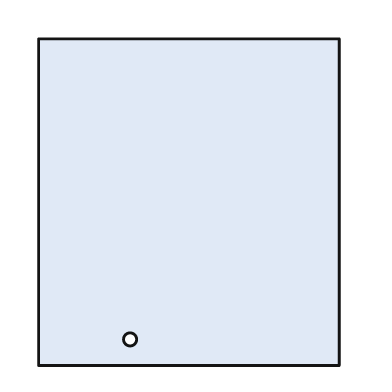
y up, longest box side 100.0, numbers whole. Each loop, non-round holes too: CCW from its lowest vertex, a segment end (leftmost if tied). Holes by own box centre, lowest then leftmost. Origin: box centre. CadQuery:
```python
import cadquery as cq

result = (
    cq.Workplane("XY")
    .moveTo(-46.0, -50.0)
    .lineTo(46.0, -50.0)
    .lineTo(46.0, 50.0)
    .lineTo(-46.0, 50.0)
    .close()
    .moveTo(-18.0, -42.0)
    .circle(2.0)
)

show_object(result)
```